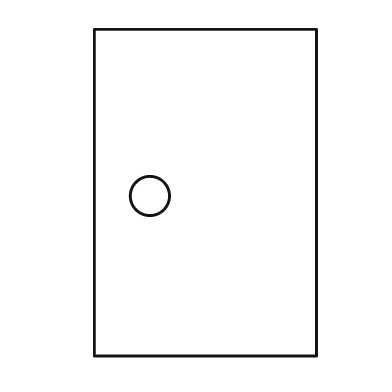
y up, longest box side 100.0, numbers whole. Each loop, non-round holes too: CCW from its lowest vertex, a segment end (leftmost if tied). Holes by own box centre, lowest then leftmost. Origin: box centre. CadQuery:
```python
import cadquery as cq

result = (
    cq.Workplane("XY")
    .moveTo(-34.0, -50.0)
    .lineTo(34.0, -50.0)
    .lineTo(34.0, 50.0)
    .lineTo(-34.0, 50.0)
    .close()
    .moveTo(-17.0, -1.0)
    .circle(6.0)
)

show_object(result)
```